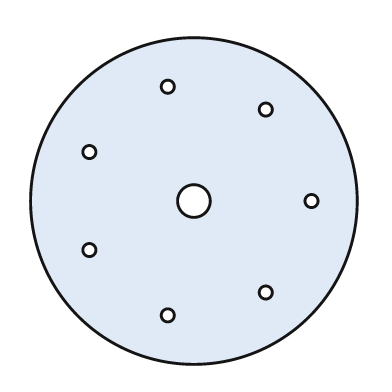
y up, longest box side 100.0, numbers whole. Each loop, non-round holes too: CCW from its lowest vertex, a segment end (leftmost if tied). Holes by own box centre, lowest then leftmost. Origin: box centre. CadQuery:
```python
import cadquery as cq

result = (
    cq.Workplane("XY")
    .moveTo(0.0, 0.0)
    .circle(50.0)
    .moveTo(-8.0, -35.0)
    .circle(2.0)
    .moveTo(22.0, -28.0)
    .circle(2.0)
    .moveTo(-32.0, -15.0)
    .circle(2.0)
    .moveTo(0.0, 0.0)
    .circle(5.0)
    .moveTo(36.0, 0.0)
    .circle(2.0)
    .moveTo(-32.0, 15.0)
    .circle(2.0)
    .moveTo(22.0, 28.0)
    .circle(2.0)
    .moveTo(-8.0, 35.0)
    .circle(2.0)
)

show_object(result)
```